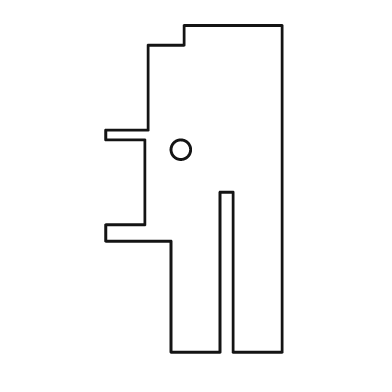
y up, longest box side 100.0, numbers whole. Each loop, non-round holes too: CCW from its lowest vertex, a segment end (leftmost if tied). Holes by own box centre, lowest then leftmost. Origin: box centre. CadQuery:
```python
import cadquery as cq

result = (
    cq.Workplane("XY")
    .moveTo(-7.0, -50.0)
    .lineTo(8.0, -50.0)
    .lineTo(8.0, -1.0)
    .lineTo(12.0, -1.0)
    .lineTo(12.0, -50.0)
    .lineTo(27.0, -50.0)
    .lineTo(27.0, 50.0)
    .lineTo(-3.0, 50.0)
    .lineTo(-3.0, 44.0)
    .lineTo(-14.0, 44.0)
    .lineTo(-14.0, 18.0)
    .lineTo(-27.0, 18.0)
    .lineTo(-27.0, 15.0)
    .lineTo(-15.0, 15.0)
    .lineTo(-15.0, -11.0)
    .lineTo(-27.0, -11.0)
    .lineTo(-27.0, -16.0)
    .lineTo(-7.0, -16.0)
    .close()
    .moveTo(-4.0, 12.0)
    .circle(3.0)
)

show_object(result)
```